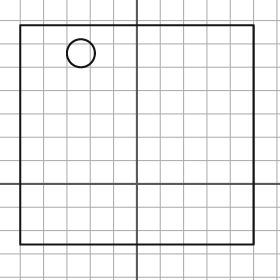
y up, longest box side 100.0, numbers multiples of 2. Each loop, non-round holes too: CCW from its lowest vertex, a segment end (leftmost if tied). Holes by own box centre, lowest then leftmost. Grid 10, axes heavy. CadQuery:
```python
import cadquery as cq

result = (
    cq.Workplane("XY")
    .moveTo(-50.0, -26.0)
    .lineTo(50.0, -26.0)
    .lineTo(50.0, 68.0)
    .lineTo(-50.0, 68.0)
    .close()
    .moveTo(-24.0, 56.0)
    .circle(6.0)
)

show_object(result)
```